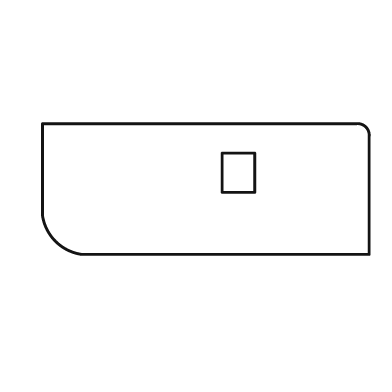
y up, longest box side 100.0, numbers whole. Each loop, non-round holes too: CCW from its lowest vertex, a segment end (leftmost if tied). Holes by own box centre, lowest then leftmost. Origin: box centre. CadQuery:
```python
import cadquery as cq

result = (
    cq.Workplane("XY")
    .moveTo(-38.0, -20.0)
    .lineTo(50.0, -20.0)
    .lineTo(50.0, 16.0)
    .threePointArc((49.0, 19.0), (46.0, 20.0))
    .lineTo(-50.0, 20.0)
    .lineTo(-50.0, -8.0)
    .threePointArc((-46.0, -16.0), (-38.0, -20.0))
    .close()
    .moveTo(5.0, -1.0)
    .lineTo(15.0, -1.0)
    .lineTo(15.0, 11.0)
    .lineTo(5.0, 11.0)
    .close()
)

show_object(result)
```